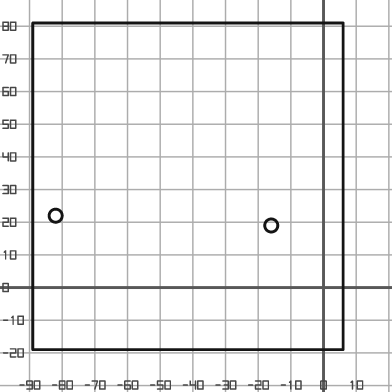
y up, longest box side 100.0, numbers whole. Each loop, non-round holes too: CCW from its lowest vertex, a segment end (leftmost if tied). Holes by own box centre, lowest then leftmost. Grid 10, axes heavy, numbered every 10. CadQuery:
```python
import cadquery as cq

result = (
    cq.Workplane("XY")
    .moveTo(-89.0, -19.0)
    .lineTo(6.0, -19.0)
    .lineTo(6.0, 81.0)
    .lineTo(-89.0, 81.0)
    .close()
    .moveTo(-16.0, 19.0)
    .circle(2.0)
    .moveTo(-82.0, 22.0)
    .circle(2.0)
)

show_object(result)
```